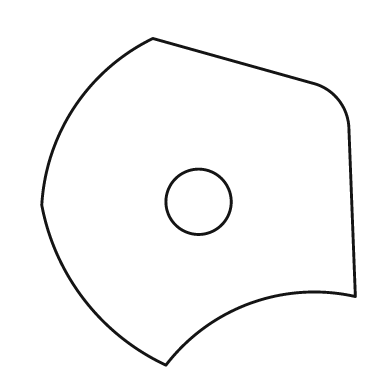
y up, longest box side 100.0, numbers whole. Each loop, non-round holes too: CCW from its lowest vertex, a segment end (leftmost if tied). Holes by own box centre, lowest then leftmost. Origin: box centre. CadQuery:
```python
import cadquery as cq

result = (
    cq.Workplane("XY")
    .moveTo(-10.0, -50.0)
    .threePointArc((16.0, -31.0), (48.0, -29.0))
    .lineTo(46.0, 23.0)
    .threePointArc((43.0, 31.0), (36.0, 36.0))
    .lineTo(-14.0, 50.0)
    .threePointArc((-38.0, 29.0), (-48.0, -1.0))
    .threePointArc((-35.0, -30.0), (-10.0, -50.0))
    .close()
    .moveTo(0.0, 0.0)
    .circle(10.0)
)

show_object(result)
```